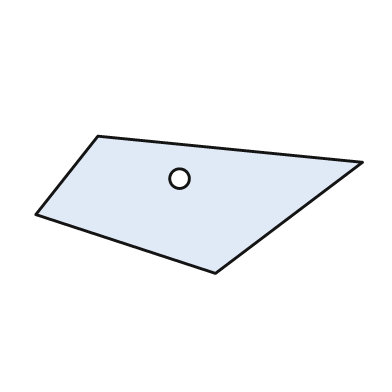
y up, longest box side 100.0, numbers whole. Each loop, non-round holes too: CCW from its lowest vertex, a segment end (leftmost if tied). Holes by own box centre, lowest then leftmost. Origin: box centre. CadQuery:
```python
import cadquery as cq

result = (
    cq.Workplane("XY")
    .moveTo(5.0, -21.0)
    .lineTo(50.0, 13.0)
    .lineTo(-31.0, 21.0)
    .lineTo(-50.0, -3.0)
    .close()
    .moveTo(-6.0, 8.0)
    .circle(3.0)
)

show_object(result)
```